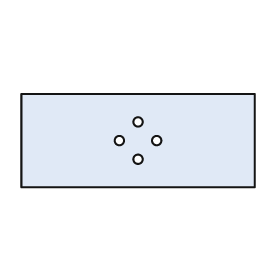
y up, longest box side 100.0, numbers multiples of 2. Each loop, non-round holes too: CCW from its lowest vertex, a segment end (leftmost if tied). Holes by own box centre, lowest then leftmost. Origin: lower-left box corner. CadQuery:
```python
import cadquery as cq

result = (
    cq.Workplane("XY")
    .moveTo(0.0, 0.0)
    .lineTo(100.0, 0.0)
    .lineTo(100.0, 40.0)
    .lineTo(0.0, 40.0)
    .close()
    .moveTo(50.0, 12.0)
    .circle(2.0)
    .moveTo(42.0, 20.0)
    .circle(2.0)
    .moveTo(58.0, 20.0)
    .circle(2.0)
    .moveTo(50.0, 28.0)
    .circle(2.0)
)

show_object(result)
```